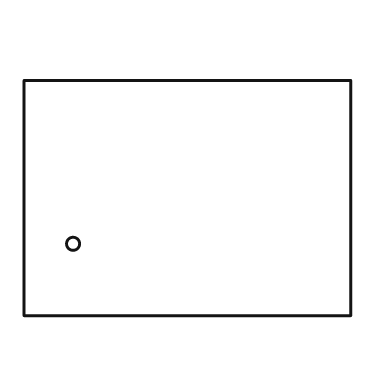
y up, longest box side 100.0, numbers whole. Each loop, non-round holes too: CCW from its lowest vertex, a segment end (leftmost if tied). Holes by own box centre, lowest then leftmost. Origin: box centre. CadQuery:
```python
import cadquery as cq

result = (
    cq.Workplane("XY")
    .moveTo(-50.0, -36.0)
    .lineTo(50.0, -36.0)
    .lineTo(50.0, 36.0)
    .lineTo(-50.0, 36.0)
    .close()
    .moveTo(-35.0, -14.0)
    .circle(2.0)
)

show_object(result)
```